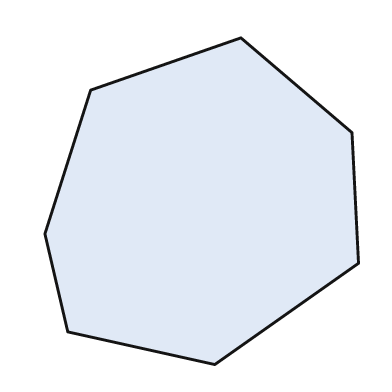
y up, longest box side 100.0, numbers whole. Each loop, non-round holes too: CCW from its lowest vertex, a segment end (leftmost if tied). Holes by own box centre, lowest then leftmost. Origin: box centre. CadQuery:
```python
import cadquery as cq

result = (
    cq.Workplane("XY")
    .moveTo(4.0, -50.0)
    .lineTo(48.0, -19.0)
    .lineTo(46.0, 21.0)
    .lineTo(12.0, 50.0)
    .lineTo(-34.0, 34.0)
    .lineTo(-48.0, -10.0)
    .lineTo(-41.0, -40.0)
    .close()
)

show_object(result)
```